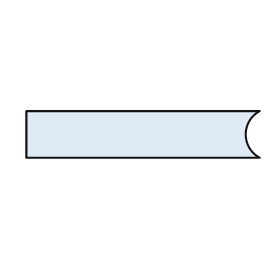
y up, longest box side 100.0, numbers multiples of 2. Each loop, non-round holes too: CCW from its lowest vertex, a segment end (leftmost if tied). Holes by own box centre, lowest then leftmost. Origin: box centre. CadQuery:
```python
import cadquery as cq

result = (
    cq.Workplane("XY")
    .moveTo(-50.0, -10.0)
    .lineTo(50.0, -10.0)
    .threePointArc((44.0, 0.0), (50.0, 10.0))
    .lineTo(-50.0, 10.0)
    .close()
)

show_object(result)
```